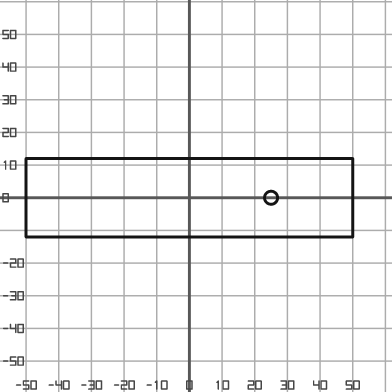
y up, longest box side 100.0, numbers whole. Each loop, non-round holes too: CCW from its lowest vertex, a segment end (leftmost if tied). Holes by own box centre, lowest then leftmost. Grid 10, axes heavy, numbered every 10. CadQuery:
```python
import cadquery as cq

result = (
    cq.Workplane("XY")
    .moveTo(-50.0, -12.0)
    .lineTo(50.0, -12.0)
    .lineTo(50.0, 12.0)
    .lineTo(-50.0, 12.0)
    .close()
    .moveTo(25.0, 0.0)
    .circle(2.0)
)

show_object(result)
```